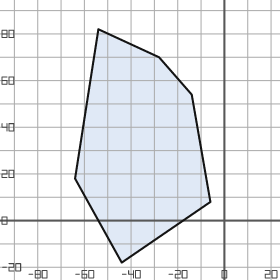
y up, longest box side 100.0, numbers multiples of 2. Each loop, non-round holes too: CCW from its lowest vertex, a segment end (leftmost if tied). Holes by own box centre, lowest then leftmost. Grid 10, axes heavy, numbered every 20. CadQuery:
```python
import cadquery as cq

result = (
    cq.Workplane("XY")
    .moveTo(-44.0, -18.0)
    .lineTo(-6.0, 8.0)
    .lineTo(-14.0, 54.0)
    .lineTo(-28.0, 70.0)
    .lineTo(-54.0, 82.0)
    .lineTo(-64.0, 18.0)
    .close()
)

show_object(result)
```